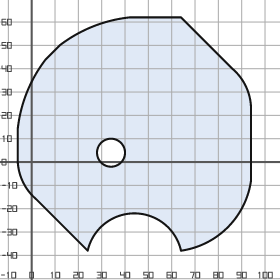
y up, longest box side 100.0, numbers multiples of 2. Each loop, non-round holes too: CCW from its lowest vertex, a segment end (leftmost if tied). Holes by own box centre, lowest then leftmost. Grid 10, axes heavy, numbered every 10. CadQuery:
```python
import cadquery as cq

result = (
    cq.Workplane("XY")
    .moveTo(24.0, -38.0)
    .threePointArc((44.0, -22.0), (64.0, -38.0))
    .threePointArc((84.0, -28.0), (94.0, -8.0))
    .lineTo(94.0, 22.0)
    .threePointArc((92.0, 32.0), (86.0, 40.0))
    .lineTo(64.0, 62.0)
    .lineTo(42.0, 62.0)
    .threePointArc((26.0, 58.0), (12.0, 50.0))
    .lineTo(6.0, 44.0)
    .threePointArc((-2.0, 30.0), (-6.0, 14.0))
    .lineTo(-6.0, 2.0)
    .threePointArc((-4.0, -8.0), (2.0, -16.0))
    .close()
    .moveTo(34.0, 4.0)
    .circle(6.0)
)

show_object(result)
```